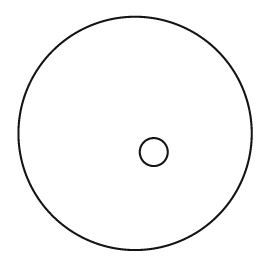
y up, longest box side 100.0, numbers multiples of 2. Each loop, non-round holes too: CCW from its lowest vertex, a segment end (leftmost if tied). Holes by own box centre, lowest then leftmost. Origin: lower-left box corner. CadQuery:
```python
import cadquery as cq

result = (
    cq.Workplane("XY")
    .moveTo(50.0, 50.0)
    .circle(50.0)
    .moveTo(58.0, 42.0)
    .circle(6.0)
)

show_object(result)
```